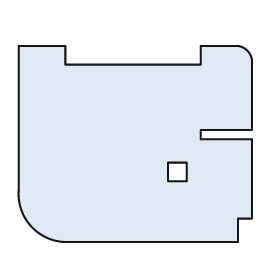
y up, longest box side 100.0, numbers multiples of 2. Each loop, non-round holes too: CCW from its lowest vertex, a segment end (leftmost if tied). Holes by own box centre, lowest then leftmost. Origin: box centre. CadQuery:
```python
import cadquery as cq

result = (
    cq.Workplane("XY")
    .moveTo(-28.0, -42.0)
    .lineTo(44.0, -42.0)
    .lineTo(44.0, -32.0)
    .lineTo(50.0, -32.0)
    .lineTo(50.0, 2.0)
    .lineTo(28.0, 2.0)
    .lineTo(28.0, 6.0)
    .lineTo(50.0, 6.0)
    .lineTo(50.0, 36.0)
    .threePointArc((48.0, 40.0), (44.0, 42.0))
    .lineTo(28.0, 42.0)
    .lineTo(28.0, 34.0)
    .lineTo(-30.0, 34.0)
    .lineTo(-30.0, 42.0)
    .lineTo(-50.0, 42.0)
    .lineTo(-50.0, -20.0)
    .threePointArc((-44.0, -36.0), (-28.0, -42.0))
    .close()
    .moveTo(14.0, -16.0)
    .lineTo(22.0, -16.0)
    .lineTo(22.0, -8.0)
    .lineTo(14.0, -8.0)
    .close()
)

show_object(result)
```